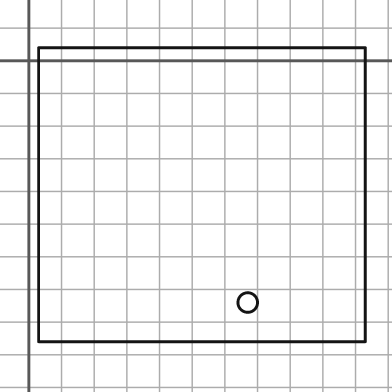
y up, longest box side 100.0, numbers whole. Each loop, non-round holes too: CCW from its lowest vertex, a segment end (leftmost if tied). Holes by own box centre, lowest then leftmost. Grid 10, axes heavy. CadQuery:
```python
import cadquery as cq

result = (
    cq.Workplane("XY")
    .moveTo(3.0, -86.0)
    .lineTo(103.0, -86.0)
    .lineTo(103.0, 4.0)
    .lineTo(3.0, 4.0)
    .close()
    .moveTo(67.0, -74.0)
    .circle(3.0)
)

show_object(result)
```